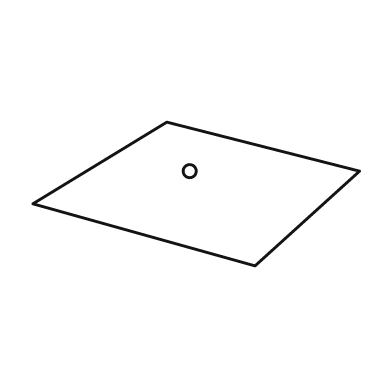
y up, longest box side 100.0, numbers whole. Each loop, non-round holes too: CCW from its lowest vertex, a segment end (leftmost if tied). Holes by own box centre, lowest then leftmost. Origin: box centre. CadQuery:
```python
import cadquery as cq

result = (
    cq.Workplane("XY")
    .moveTo(18.0, -22.0)
    .lineTo(50.0, 7.0)
    .lineTo(-9.0, 22.0)
    .lineTo(-50.0, -3.0)
    .close()
    .moveTo(-2.0, 7.0)
    .circle(2.0)
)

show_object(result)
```